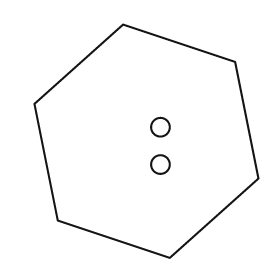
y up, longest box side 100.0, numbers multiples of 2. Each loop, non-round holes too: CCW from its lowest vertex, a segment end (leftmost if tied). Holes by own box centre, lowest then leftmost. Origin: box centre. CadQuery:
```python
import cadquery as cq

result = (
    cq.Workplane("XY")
    .moveTo(10.0, -50.0)
    .lineTo(48.0, -16.0)
    .lineTo(38.0, 34.0)
    .lineTo(-10.0, 50.0)
    .lineTo(-48.0, 16.0)
    .lineTo(-38.0, -34.0)
    .close()
    .moveTo(6.0, -10.0)
    .circle(4.0)
    .moveTo(6.0, 6.0)
    .circle(4.0)
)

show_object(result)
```